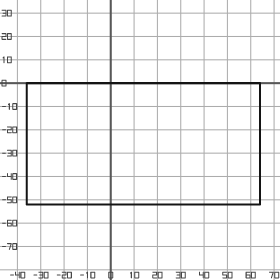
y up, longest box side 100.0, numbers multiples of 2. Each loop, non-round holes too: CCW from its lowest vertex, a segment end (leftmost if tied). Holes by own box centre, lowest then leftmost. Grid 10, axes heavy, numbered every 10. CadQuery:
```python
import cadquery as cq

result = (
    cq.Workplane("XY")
    .moveTo(-36.0, -52.0)
    .lineTo(64.0, -52.0)
    .lineTo(64.0, 0.0)
    .lineTo(-36.0, 0.0)
    .close()
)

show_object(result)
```